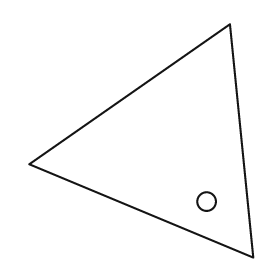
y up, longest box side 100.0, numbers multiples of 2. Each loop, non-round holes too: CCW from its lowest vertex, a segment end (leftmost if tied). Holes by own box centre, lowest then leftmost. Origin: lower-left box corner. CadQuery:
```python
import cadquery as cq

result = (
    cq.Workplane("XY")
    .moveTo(96.0, 0.0)
    .lineTo(86.0, 100.0)
    .lineTo(0.0, 40.0)
    .close()
    .moveTo(76.0, 24.0)
    .circle(4.0)
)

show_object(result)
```